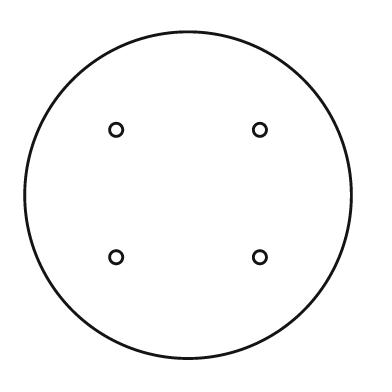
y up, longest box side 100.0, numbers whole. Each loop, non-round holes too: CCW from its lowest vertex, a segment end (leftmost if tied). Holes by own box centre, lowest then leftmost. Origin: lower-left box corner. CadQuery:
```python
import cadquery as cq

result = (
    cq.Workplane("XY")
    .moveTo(50.0, 50.0)
    .circle(50.0)
    .moveTo(28.0, 31.0)
    .circle(2.0)
    .moveTo(72.0, 31.0)
    .circle(2.0)
    .moveTo(28.0, 70.0)
    .circle(2.0)
    .moveTo(72.0, 70.0)
    .circle(2.0)
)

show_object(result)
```